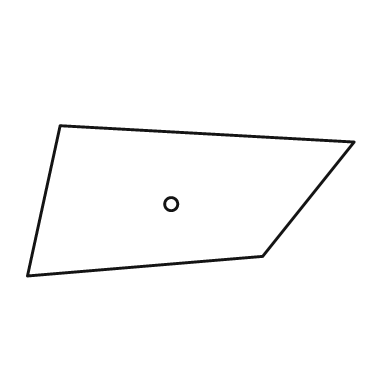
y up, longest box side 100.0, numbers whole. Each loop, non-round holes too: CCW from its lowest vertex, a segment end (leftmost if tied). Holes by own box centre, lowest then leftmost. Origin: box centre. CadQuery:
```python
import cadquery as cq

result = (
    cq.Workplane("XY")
    .moveTo(-50.0, -23.0)
    .lineTo(22.0, -17.0)
    .lineTo(50.0, 18.0)
    .lineTo(-40.0, 23.0)
    .close()
    .moveTo(-6.0, -1.0)
    .circle(2.0)
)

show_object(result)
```